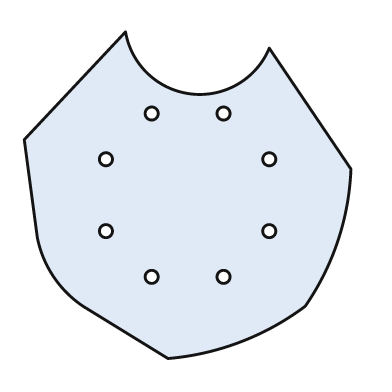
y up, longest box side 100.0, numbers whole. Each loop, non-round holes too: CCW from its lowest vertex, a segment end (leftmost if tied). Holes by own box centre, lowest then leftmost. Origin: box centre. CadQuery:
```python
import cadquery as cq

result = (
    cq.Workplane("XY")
    .moveTo(-6.0, -50.0)
    .threePointArc((16.0, -45.0), (36.0, -34.0))
    .threePointArc((46.0, -14.0), (50.0, 8.0))
    .lineTo(25.0, 45.0)
    .threePointArc((1.0, 31.0), (-19.0, 50.0))
    .lineTo(-50.0, 17.0)
    .lineTo(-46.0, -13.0)
    .threePointArc((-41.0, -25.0), (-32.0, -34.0))
    .close()
    .moveTo(-11.0, -25.0)
    .circle(2.0)
    .moveTo(11.0, -25.0)
    .circle(2.0)
    .moveTo(-25.0, -11.0)
    .circle(2.0)
    .moveTo(25.0, -11.0)
    .circle(2.0)
    .moveTo(-25.0, 11.0)
    .circle(2.0)
    .moveTo(25.0, 11.0)
    .circle(2.0)
    .moveTo(-11.0, 25.0)
    .circle(2.0)
    .moveTo(11.0, 25.0)
    .circle(2.0)
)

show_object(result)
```